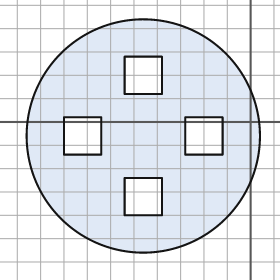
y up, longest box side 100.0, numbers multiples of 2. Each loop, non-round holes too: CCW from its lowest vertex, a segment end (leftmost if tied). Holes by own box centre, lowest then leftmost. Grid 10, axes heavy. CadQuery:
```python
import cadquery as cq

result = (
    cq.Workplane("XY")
    .moveTo(-46.0, -6.0)
    .circle(50.0)
    .moveTo(-54.0, -40.0)
    .lineTo(-38.0, -40.0)
    .lineTo(-38.0, -24.0)
    .lineTo(-54.0, -24.0)
    .close()
    .moveTo(-80.0, -14.0)
    .lineTo(-64.0, -14.0)
    .lineTo(-64.0, 2.0)
    .lineTo(-80.0, 2.0)
    .close()
    .moveTo(-28.0, -14.0)
    .lineTo(-12.0, -14.0)
    .lineTo(-12.0, 2.0)
    .lineTo(-28.0, 2.0)
    .close()
    .moveTo(-54.0, 12.0)
    .lineTo(-38.0, 12.0)
    .lineTo(-38.0, 28.0)
    .lineTo(-54.0, 28.0)
    .close()
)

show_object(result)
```